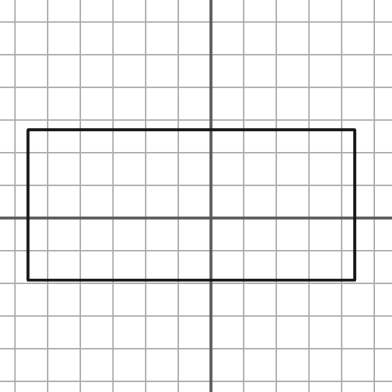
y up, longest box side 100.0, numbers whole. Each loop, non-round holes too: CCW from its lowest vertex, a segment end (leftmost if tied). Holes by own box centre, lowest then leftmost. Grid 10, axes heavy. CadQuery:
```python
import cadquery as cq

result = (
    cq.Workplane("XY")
    .moveTo(-56.0, -19.0)
    .lineTo(44.0, -19.0)
    .lineTo(44.0, 27.0)
    .lineTo(-56.0, 27.0)
    .close()
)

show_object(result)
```